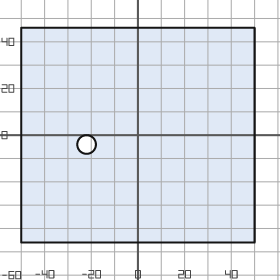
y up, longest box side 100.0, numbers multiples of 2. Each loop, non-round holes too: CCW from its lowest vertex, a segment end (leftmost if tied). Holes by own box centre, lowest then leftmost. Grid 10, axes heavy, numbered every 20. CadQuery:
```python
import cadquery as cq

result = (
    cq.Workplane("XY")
    .moveTo(-50.0, -46.0)
    .lineTo(50.0, -46.0)
    .lineTo(50.0, 46.0)
    .lineTo(-50.0, 46.0)
    .close()
    .moveTo(-22.0, -4.0)
    .circle(4.0)
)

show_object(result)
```